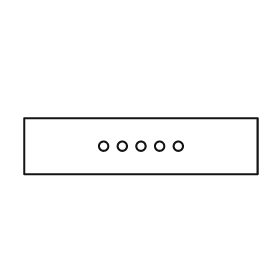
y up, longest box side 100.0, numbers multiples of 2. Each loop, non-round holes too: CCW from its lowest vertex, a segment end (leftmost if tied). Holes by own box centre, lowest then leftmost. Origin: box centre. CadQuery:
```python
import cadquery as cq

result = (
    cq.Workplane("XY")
    .moveTo(-50.0, -12.0)
    .lineTo(50.0, -12.0)
    .lineTo(50.0, 12.0)
    .lineTo(-50.0, 12.0)
    .close()
    .moveTo(-16.0, 0.0)
    .circle(2.0)
    .moveTo(-8.0, 0.0)
    .circle(2.0)
    .moveTo(0.0, 0.0)
    .circle(2.0)
    .moveTo(8.0, 0.0)
    .circle(2.0)
    .moveTo(16.0, 0.0)
    .circle(2.0)
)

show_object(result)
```